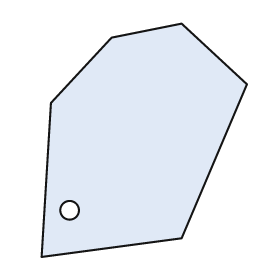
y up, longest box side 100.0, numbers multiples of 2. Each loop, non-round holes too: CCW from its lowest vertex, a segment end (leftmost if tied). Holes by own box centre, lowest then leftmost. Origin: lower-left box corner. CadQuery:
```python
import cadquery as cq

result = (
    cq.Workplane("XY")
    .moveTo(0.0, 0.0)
    .lineTo(60.0, 8.0)
    .lineTo(88.0, 74.0)
    .lineTo(60.0, 100.0)
    .lineTo(30.0, 94.0)
    .lineTo(4.0, 66.0)
    .close()
    .moveTo(12.0, 20.0)
    .circle(4.0)
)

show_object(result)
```